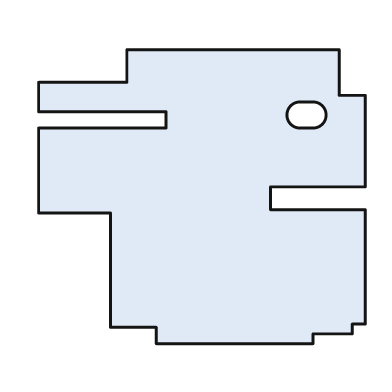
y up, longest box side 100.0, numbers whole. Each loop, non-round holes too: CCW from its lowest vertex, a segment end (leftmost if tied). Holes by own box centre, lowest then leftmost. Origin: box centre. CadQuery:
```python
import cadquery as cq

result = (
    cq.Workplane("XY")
    .moveTo(-14.0, -45.0)
    .lineTo(34.0, -45.0)
    .lineTo(34.0, -42.0)
    .lineTo(46.0, -42.0)
    .lineTo(46.0, -39.0)
    .lineTo(50.0, -39.0)
    .lineTo(50.0, -4.0)
    .lineTo(21.0, -4.0)
    .lineTo(21.0, 3.0)
    .lineTo(50.0, 3.0)
    .lineTo(50.0, 31.0)
    .lineTo(42.0, 31.0)
    .lineTo(42.0, 45.0)
    .lineTo(-23.0, 45.0)
    .lineTo(-23.0, 35.0)
    .lineTo(-50.0, 35.0)
    .lineTo(-50.0, 26.0)
    .lineTo(-11.0, 26.0)
    .lineTo(-11.0, 21.0)
    .lineTo(-50.0, 21.0)
    .lineTo(-50.0, -5.0)
    .lineTo(-28.0, -5.0)
    .lineTo(-28.0, -40.0)
    .lineTo(-14.0, -40.0)
    .close()
    .moveTo(30.0, 21.0)
    .lineTo(34.0, 21.0)
    .threePointArc((38.0, 25.0), (34.0, 29.0))
    .lineTo(30.0, 29.0)
    .threePointArc((26.0, 25.0), (30.0, 21.0))
    .close()
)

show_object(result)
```